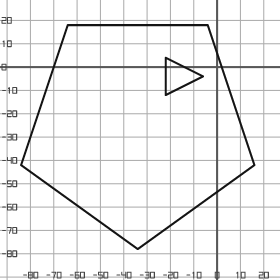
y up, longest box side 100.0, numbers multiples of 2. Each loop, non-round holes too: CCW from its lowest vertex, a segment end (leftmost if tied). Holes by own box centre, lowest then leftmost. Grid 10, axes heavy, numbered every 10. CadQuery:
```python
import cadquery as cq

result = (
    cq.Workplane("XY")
    .moveTo(-34.0, -78.0)
    .lineTo(16.0, -42.0)
    .lineTo(-4.0, 18.0)
    .lineTo(-64.0, 18.0)
    .lineTo(-84.0, -42.0)
    .close()
    .moveTo(-22.0, -12.0)
    .lineTo(-6.0, -4.0)
    .lineTo(-22.0, 4.0)
    .close()
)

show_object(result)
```